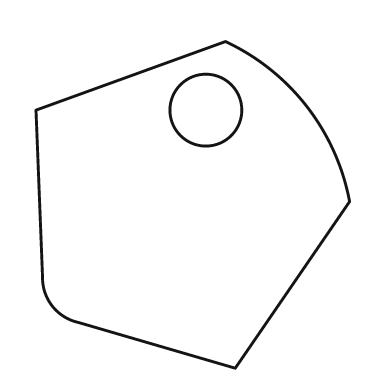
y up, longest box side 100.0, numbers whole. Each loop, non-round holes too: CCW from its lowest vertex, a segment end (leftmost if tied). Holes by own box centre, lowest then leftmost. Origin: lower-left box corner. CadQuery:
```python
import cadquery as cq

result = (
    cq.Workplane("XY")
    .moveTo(61.0, 0.0)
    .lineTo(96.0, 51.0)
    .threePointArc((83.0, 80.0), (58.0, 100.0))
    .lineTo(0.0, 79.0)
    .lineTo(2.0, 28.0)
    .threePointArc((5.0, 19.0), (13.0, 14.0))
    .close()
    .moveTo(52.0, 79.0)
    .circle(11.0)
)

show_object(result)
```